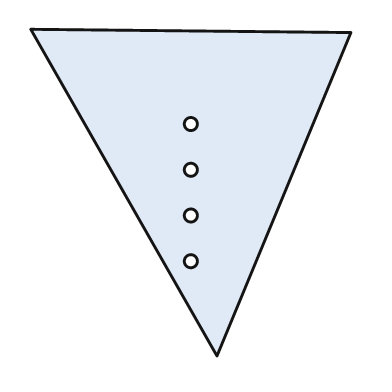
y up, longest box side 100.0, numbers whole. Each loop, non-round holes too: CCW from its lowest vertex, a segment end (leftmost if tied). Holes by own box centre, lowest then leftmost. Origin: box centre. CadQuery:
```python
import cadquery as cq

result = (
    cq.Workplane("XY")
    .moveTo(8.0, -50.0)
    .lineTo(49.0, 49.0)
    .lineTo(-49.0, 50.0)
    .close()
    .moveTo(0.0, -21.0)
    .circle(2.0)
    .moveTo(0.0, -7.0)
    .circle(2.0)
    .moveTo(0.0, 7.0)
    .circle(2.0)
    .moveTo(0.0, 21.0)
    .circle(2.0)
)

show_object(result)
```